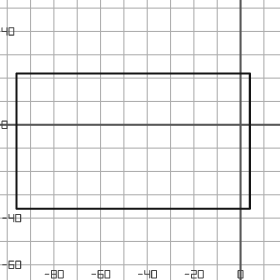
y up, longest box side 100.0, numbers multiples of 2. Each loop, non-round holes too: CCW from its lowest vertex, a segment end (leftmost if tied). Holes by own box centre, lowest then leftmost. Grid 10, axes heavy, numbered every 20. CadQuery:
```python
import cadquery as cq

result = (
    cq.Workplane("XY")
    .moveTo(-96.0, -36.0)
    .lineTo(4.0, -36.0)
    .lineTo(4.0, 22.0)
    .lineTo(-96.0, 22.0)
    .close()
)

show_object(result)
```